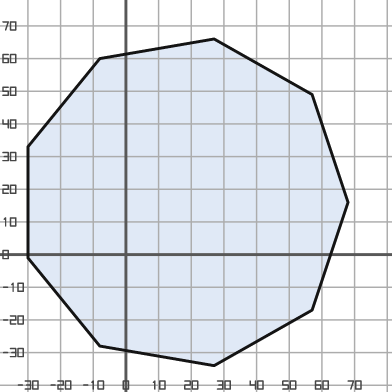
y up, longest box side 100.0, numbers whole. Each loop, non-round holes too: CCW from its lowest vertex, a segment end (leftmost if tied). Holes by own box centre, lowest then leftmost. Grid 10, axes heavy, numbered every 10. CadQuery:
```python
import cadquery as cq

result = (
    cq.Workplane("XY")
    .moveTo(27.0, -34.0)
    .lineTo(57.0, -17.0)
    .lineTo(68.0, 16.0)
    .lineTo(57.0, 49.0)
    .lineTo(27.0, 66.0)
    .lineTo(-8.0, 60.0)
    .lineTo(-30.0, 33.0)
    .lineTo(-30.0, -1.0)
    .lineTo(-8.0, -28.0)
    .close()
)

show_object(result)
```